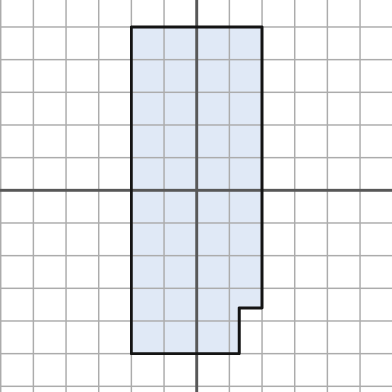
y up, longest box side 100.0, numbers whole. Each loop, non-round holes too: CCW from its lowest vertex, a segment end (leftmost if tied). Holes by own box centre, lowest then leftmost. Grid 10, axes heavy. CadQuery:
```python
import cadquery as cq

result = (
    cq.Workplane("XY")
    .moveTo(-20.0, -50.0)
    .lineTo(13.0, -50.0)
    .lineTo(13.0, -36.0)
    .lineTo(20.0, -36.0)
    .lineTo(20.0, 50.0)
    .lineTo(-20.0, 50.0)
    .close()
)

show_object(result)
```